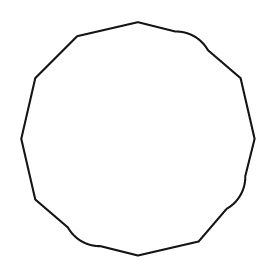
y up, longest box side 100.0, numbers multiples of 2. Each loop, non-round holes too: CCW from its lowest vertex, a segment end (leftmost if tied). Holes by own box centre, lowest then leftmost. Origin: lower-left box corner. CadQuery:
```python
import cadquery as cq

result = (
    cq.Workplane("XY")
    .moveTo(50.0, 0.0)
    .lineTo(76.0, 6.0)
    .lineTo(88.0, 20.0)
    .threePointArc((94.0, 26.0), (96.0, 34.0))
    .lineTo(100.0, 50.0)
    .lineTo(94.0, 76.0)
    .lineTo(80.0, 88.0)
    .threePointArc((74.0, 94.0), (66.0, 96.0))
    .lineTo(50.0, 100.0)
    .lineTo(24.0, 94.0)
    .lineTo(6.0, 76.0)
    .lineTo(0.0, 50.0)
    .lineTo(6.0, 24.0)
    .lineTo(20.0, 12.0)
    .threePointArc((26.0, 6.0), (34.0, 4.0))
    .close()
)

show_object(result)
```